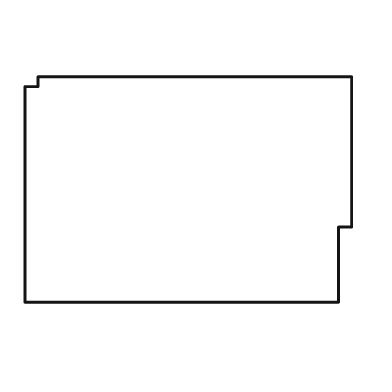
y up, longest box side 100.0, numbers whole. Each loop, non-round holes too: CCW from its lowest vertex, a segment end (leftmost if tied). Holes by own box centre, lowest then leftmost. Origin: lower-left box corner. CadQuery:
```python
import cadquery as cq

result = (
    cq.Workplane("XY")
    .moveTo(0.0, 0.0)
    .lineTo(96.0, 0.0)
    .lineTo(96.0, 23.0)
    .lineTo(100.0, 23.0)
    .lineTo(100.0, 69.0)
    .lineTo(4.0, 69.0)
    .lineTo(4.0, 66.0)
    .lineTo(0.0, 66.0)
    .close()
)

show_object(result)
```